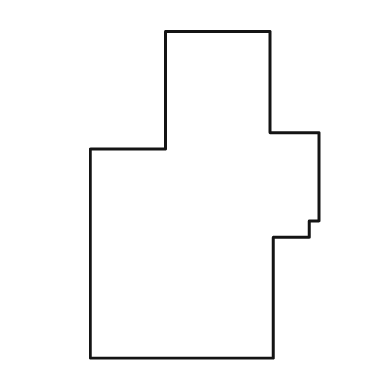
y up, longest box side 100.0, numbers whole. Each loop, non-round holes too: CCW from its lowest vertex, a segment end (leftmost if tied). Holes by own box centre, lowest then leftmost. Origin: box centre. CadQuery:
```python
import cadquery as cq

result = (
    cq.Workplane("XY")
    .moveTo(-35.0, -50.0)
    .lineTo(21.0, -50.0)
    .lineTo(21.0, -13.0)
    .lineTo(32.0, -13.0)
    .lineTo(32.0, -8.0)
    .lineTo(35.0, -8.0)
    .lineTo(35.0, 19.0)
    .lineTo(20.0, 19.0)
    .lineTo(20.0, 50.0)
    .lineTo(-12.0, 50.0)
    .lineTo(-12.0, 14.0)
    .lineTo(-35.0, 14.0)
    .close()
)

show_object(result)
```